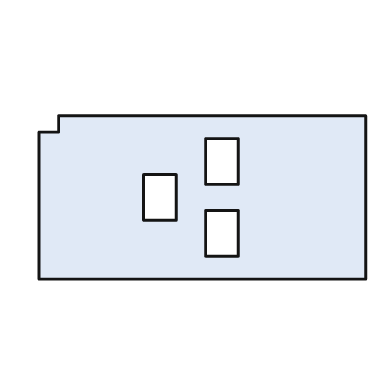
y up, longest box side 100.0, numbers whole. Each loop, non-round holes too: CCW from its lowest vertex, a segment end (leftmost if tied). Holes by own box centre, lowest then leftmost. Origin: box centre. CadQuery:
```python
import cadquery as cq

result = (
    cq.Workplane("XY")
    .moveTo(-50.0, -25.0)
    .lineTo(50.0, -25.0)
    .lineTo(50.0, 25.0)
    .lineTo(-44.0, 25.0)
    .lineTo(-44.0, 20.0)
    .lineTo(-50.0, 20.0)
    .close()
    .moveTo(1.0, -18.0)
    .lineTo(11.0, -18.0)
    .lineTo(11.0, -4.0)
    .lineTo(1.0, -4.0)
    .close()
    .moveTo(-18.0, -7.0)
    .lineTo(-8.0, -7.0)
    .lineTo(-8.0, 7.0)
    .lineTo(-18.0, 7.0)
    .close()
    .moveTo(1.0, 4.0)
    .lineTo(11.0, 4.0)
    .lineTo(11.0, 18.0)
    .lineTo(1.0, 18.0)
    .close()
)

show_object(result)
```